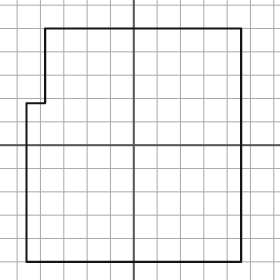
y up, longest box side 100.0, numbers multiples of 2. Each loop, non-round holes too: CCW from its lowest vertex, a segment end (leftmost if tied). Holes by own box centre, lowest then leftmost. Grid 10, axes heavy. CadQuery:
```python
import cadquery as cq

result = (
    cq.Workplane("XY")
    .moveTo(-46.0, -50.0)
    .lineTo(46.0, -50.0)
    .lineTo(46.0, 50.0)
    .lineTo(-38.0, 50.0)
    .lineTo(-38.0, 18.0)
    .lineTo(-46.0, 18.0)
    .close()
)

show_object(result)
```